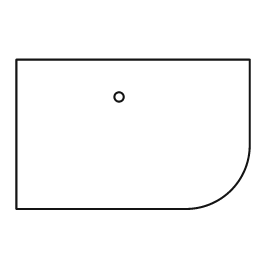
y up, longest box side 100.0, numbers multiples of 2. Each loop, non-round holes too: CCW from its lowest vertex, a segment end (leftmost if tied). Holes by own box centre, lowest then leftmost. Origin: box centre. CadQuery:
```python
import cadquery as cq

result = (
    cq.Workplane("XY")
    .moveTo(-50.0, -32.0)
    .lineTo(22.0, -32.0)
    .threePointArc((42.0, -24.0), (50.0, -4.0))
    .lineTo(50.0, 32.0)
    .lineTo(-50.0, 32.0)
    .close()
    .moveTo(-6.0, 16.0)
    .circle(2.0)
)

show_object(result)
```